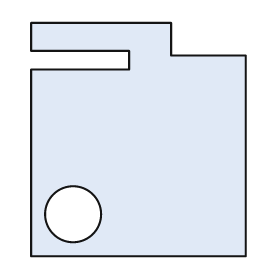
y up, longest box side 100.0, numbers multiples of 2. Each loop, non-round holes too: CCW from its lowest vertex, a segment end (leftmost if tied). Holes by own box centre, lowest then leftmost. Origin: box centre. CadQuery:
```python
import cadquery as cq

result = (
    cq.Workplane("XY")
    .moveTo(-46.0, -50.0)
    .lineTo(46.0, -50.0)
    .lineTo(46.0, 36.0)
    .lineTo(14.0, 36.0)
    .lineTo(14.0, 50.0)
    .lineTo(-46.0, 50.0)
    .lineTo(-46.0, 38.0)
    .lineTo(-4.0, 38.0)
    .lineTo(-4.0, 30.0)
    .lineTo(-46.0, 30.0)
    .close()
    .moveTo(-28.0, -32.0)
    .circle(12.0)
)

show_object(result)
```